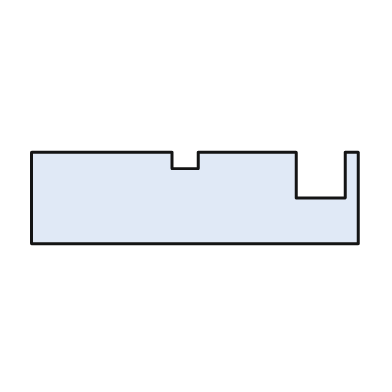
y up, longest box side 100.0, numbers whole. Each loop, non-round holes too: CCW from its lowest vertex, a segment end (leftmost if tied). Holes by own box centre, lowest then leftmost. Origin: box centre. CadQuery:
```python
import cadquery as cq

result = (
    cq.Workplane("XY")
    .moveTo(-50.0, -14.0)
    .lineTo(50.0, -14.0)
    .lineTo(50.0, 14.0)
    .lineTo(46.0, 14.0)
    .lineTo(46.0, 0.0)
    .lineTo(31.0, 0.0)
    .lineTo(31.0, 14.0)
    .lineTo(1.0, 14.0)
    .lineTo(1.0, 9.0)
    .lineTo(-7.0, 9.0)
    .lineTo(-7.0, 14.0)
    .lineTo(-50.0, 14.0)
    .close()
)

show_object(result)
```